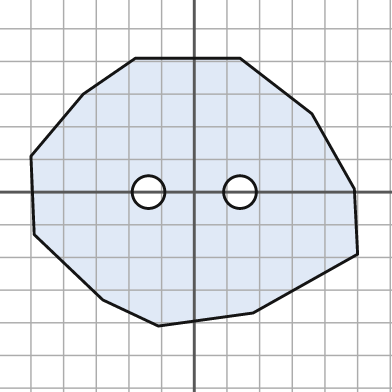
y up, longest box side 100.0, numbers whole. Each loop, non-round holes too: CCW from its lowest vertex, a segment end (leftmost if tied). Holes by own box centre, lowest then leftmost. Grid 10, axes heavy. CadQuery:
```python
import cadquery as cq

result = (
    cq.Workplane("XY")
    .moveTo(-11.0, -41.0)
    .lineTo(18.0, -37.0)
    .lineTo(50.0, -19.0)
    .lineTo(49.0, 1.0)
    .lineTo(36.0, 24.0)
    .lineTo(14.0, 41.0)
    .lineTo(-18.0, 41.0)
    .lineTo(-34.0, 30.0)
    .lineTo(-50.0, 11.0)
    .lineTo(-49.0, -13.0)
    .lineTo(-28.0, -33.0)
    .close()
    .moveTo(-14.0, 0.0)
    .circle(5.0)
    .moveTo(14.0, 0.0)
    .circle(5.0)
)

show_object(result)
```